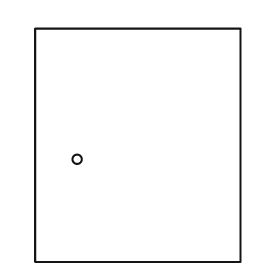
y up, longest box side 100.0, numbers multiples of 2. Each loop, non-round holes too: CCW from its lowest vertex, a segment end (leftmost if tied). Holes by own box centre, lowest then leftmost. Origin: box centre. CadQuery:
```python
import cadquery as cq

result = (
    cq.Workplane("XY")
    .moveTo(-44.0, -50.0)
    .lineTo(44.0, -50.0)
    .lineTo(44.0, 50.0)
    .lineTo(-44.0, 50.0)
    .close()
    .moveTo(-26.0, -6.0)
    .circle(2.0)
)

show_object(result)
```